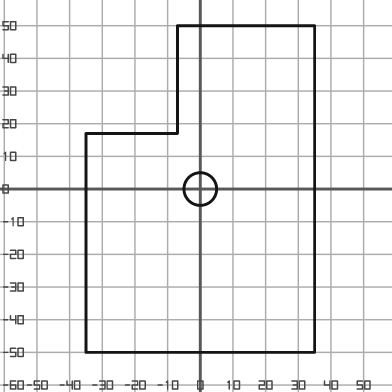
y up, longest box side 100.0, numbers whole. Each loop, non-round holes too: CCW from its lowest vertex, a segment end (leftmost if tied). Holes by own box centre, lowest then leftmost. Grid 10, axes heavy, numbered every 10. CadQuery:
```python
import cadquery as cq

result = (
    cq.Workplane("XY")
    .moveTo(-35.0, -50.0)
    .lineTo(35.0, -50.0)
    .lineTo(35.0, 50.0)
    .lineTo(-7.0, 50.0)
    .lineTo(-7.0, 17.0)
    .lineTo(-35.0, 17.0)
    .close()
    .moveTo(0.0, 0.0)
    .circle(5.0)
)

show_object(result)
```